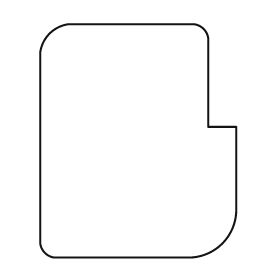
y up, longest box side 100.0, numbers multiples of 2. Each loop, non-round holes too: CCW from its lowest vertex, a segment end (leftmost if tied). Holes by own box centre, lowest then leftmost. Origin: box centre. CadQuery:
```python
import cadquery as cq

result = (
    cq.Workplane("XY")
    .moveTo(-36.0, -50.0)
    .lineTo(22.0, -50.0)
    .threePointArc((36.0, -44.0), (42.0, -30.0))
    .lineTo(42.0, 6.0)
    .lineTo(30.0, 6.0)
    .lineTo(30.0, 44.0)
    .threePointArc((28.0, 48.0), (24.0, 50.0))
    .lineTo(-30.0, 50.0)
    .threePointArc((-38.0, 46.0), (-42.0, 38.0))
    .lineTo(-42.0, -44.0)
    .threePointArc((-40.0, -48.0), (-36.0, -50.0))
    .close()
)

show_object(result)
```